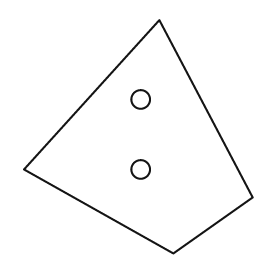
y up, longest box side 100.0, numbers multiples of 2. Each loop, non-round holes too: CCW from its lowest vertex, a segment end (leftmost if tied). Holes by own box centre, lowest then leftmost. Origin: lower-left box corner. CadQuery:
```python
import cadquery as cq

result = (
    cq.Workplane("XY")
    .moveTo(64.0, 0.0)
    .lineTo(98.0, 24.0)
    .lineTo(58.0, 100.0)
    .lineTo(0.0, 36.0)
    .close()
    .moveTo(50.0, 36.0)
    .circle(4.0)
    .moveTo(50.0, 66.0)
    .circle(4.0)
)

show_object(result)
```